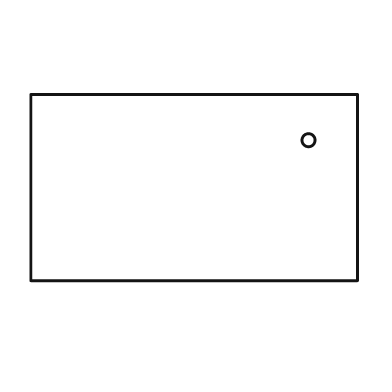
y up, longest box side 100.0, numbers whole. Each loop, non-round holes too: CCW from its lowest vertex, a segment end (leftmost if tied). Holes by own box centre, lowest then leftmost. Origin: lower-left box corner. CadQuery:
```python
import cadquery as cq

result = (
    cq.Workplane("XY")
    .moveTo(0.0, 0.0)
    .lineTo(100.0, 0.0)
    .lineTo(100.0, 57.0)
    .lineTo(0.0, 57.0)
    .close()
    .moveTo(85.0, 43.0)
    .circle(2.0)
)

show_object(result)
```